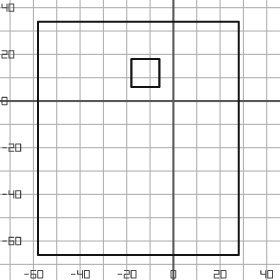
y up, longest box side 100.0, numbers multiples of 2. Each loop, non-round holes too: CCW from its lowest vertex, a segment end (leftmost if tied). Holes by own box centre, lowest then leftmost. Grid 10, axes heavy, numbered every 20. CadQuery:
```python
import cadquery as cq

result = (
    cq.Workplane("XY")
    .moveTo(-58.0, -66.0)
    .lineTo(28.0, -66.0)
    .lineTo(28.0, 34.0)
    .lineTo(-58.0, 34.0)
    .close()
    .moveTo(-18.0, 6.0)
    .lineTo(-6.0, 6.0)
    .lineTo(-6.0, 18.0)
    .lineTo(-18.0, 18.0)
    .close()
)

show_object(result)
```